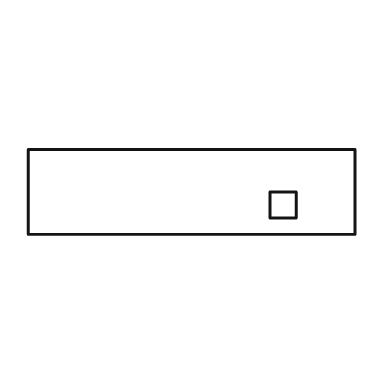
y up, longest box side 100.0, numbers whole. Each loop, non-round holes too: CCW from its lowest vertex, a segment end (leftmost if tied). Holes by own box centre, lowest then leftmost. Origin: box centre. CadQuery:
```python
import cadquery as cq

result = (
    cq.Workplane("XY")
    .moveTo(-50.0, -13.0)
    .lineTo(50.0, -13.0)
    .lineTo(50.0, 13.0)
    .lineTo(-50.0, 13.0)
    .close()
    .moveTo(24.0, -8.0)
    .lineTo(32.0, -8.0)
    .lineTo(32.0, 0.0)
    .lineTo(24.0, 0.0)
    .close()
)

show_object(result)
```